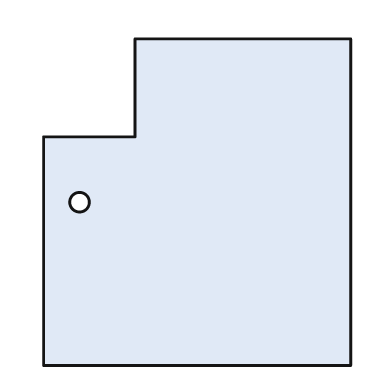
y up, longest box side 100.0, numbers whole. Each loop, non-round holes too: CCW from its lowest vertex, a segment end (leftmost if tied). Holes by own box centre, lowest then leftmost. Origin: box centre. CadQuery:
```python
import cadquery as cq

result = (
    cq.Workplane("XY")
    .moveTo(-47.0, -50.0)
    .lineTo(47.0, -50.0)
    .lineTo(47.0, 50.0)
    .lineTo(-19.0, 50.0)
    .lineTo(-19.0, 20.0)
    .lineTo(-47.0, 20.0)
    .close()
    .moveTo(-36.0, 0.0)
    .circle(3.0)
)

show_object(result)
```